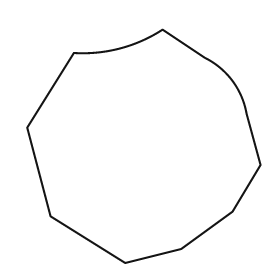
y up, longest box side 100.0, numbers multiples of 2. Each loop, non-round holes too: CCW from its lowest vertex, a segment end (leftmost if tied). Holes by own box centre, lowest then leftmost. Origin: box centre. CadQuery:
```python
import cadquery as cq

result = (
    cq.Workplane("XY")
    .moveTo(-8.0, -50.0)
    .lineTo(16.0, -44.0)
    .lineTo(38.0, -28.0)
    .lineTo(50.0, -8.0)
    .lineTo(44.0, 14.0)
    .threePointArc((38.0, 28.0), (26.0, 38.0))
    .lineTo(8.0, 50.0)
    .threePointArc((-10.0, 42.0), (-30.0, 40.0))
    .lineTo(-50.0, 8.0)
    .lineTo(-40.0, -30.0)
    .close()
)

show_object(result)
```